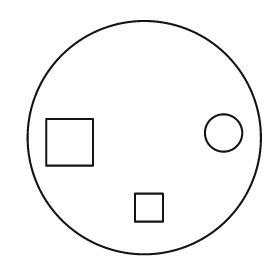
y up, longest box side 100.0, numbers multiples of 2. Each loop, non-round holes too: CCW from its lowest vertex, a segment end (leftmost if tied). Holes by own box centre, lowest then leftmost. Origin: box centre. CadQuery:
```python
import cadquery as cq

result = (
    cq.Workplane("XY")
    .moveTo(0.0, 0.0)
    .circle(50.0)
    .moveTo(-4.0, -36.0)
    .lineTo(8.0, -36.0)
    .lineTo(8.0, -24.0)
    .lineTo(-4.0, -24.0)
    .close()
    .moveTo(-42.0, -12.0)
    .lineTo(-22.0, -12.0)
    .lineTo(-22.0, 8.0)
    .lineTo(-42.0, 8.0)
    .close()
    .moveTo(34.0, 2.0)
    .circle(8.0)
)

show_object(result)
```